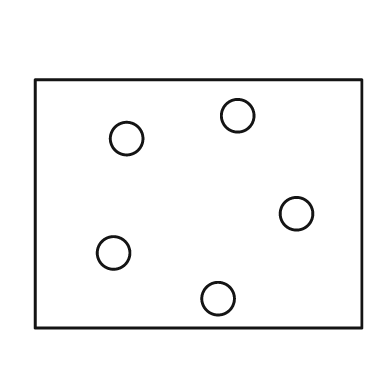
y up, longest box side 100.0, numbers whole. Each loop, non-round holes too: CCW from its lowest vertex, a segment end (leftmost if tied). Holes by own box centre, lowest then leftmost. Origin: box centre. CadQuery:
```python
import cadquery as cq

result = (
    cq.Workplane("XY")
    .moveTo(-50.0, -38.0)
    .lineTo(50.0, -38.0)
    .lineTo(50.0, 38.0)
    .lineTo(-50.0, 38.0)
    .close()
    .moveTo(6.0, -29.0)
    .circle(5.0)
    .moveTo(-26.0, -15.0)
    .circle(5.0)
    .moveTo(30.0, -3.0)
    .circle(5.0)
    .moveTo(-22.0, 20.0)
    .circle(5.0)
    .moveTo(12.0, 27.0)
    .circle(5.0)
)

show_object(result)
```